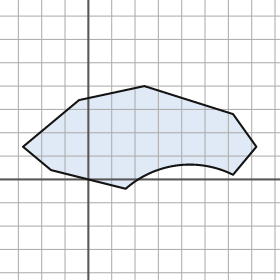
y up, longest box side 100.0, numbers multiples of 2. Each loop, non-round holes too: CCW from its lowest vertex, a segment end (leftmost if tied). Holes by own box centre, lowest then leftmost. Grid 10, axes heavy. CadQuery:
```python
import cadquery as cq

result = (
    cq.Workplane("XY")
    .moveTo(16.0, -4.0)
    .threePointArc((38.0, 6.0), (62.0, 2.0))
    .lineTo(72.0, 14.0)
    .lineTo(62.0, 28.0)
    .lineTo(24.0, 40.0)
    .lineTo(-4.0, 34.0)
    .lineTo(-28.0, 14.0)
    .lineTo(-16.0, 4.0)
    .close()
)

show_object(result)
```